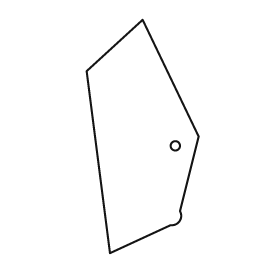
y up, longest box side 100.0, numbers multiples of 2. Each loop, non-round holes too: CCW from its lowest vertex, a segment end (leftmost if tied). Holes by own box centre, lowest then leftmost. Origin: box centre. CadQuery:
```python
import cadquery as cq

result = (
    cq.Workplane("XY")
    .moveTo(-14.0, -50.0)
    .lineTo(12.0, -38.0)
    .threePointArc((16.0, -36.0), (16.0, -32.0))
    .lineTo(24.0, 0.0)
    .lineTo(0.0, 50.0)
    .lineTo(-24.0, 28.0)
    .close()
    .moveTo(14.0, -4.0)
    .circle(2.0)
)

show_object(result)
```